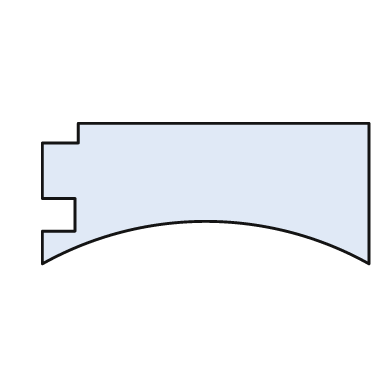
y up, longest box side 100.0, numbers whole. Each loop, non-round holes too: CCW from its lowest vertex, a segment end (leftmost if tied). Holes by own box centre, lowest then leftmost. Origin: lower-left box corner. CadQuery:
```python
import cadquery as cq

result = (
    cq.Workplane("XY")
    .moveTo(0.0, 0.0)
    .threePointArc((50.0, 13.0), (100.0, 0.0))
    .lineTo(100.0, 43.0)
    .lineTo(11.0, 43.0)
    .lineTo(11.0, 37.0)
    .lineTo(0.0, 37.0)
    .lineTo(0.0, 20.0)
    .lineTo(10.0, 20.0)
    .lineTo(10.0, 10.0)
    .lineTo(0.0, 10.0)
    .close()
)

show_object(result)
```